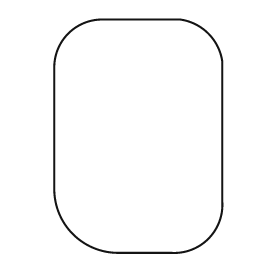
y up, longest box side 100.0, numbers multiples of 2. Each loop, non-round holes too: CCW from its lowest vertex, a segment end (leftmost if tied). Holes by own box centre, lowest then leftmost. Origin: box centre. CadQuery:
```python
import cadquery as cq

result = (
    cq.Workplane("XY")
    .moveTo(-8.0, -50.0)
    .lineTo(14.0, -50.0)
    .threePointArc((30.0, -44.0), (36.0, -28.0))
    .lineTo(36.0, 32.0)
    .threePointArc((30.0, 44.0), (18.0, 50.0))
    .lineTo(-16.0, 50.0)
    .threePointArc((-30.0, 44.0), (-36.0, 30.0))
    .lineTo(-36.0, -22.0)
    .threePointArc((-28.0, -42.0), (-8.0, -50.0))
    .close()
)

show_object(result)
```